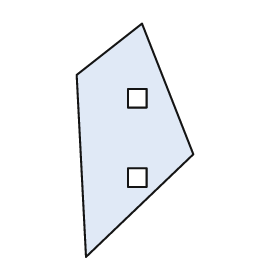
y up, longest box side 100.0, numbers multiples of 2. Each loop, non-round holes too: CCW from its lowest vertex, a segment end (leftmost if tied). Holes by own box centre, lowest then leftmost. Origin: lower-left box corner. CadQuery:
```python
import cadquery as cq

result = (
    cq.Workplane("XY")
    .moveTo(4.0, 0.0)
    .lineTo(50.0, 44.0)
    .lineTo(28.0, 100.0)
    .lineTo(0.0, 78.0)
    .close()
    .moveTo(22.0, 30.0)
    .lineTo(30.0, 30.0)
    .lineTo(30.0, 38.0)
    .lineTo(22.0, 38.0)
    .close()
    .moveTo(22.0, 64.0)
    .lineTo(30.0, 64.0)
    .lineTo(30.0, 72.0)
    .lineTo(22.0, 72.0)
    .close()
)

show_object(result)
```